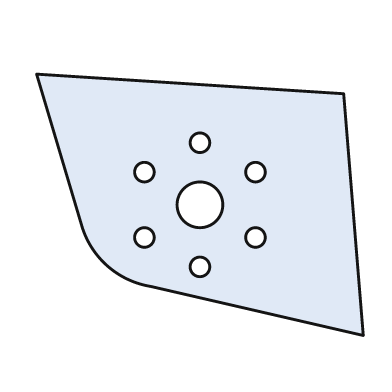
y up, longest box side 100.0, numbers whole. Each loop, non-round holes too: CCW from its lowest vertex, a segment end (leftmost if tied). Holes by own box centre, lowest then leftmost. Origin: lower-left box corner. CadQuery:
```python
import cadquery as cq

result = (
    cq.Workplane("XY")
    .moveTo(100.0, 0.0)
    .lineTo(94.0, 74.0)
    .lineTo(0.0, 80.0)
    .lineTo(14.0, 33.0)
    .threePointArc((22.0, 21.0), (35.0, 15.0))
    .close()
    .moveTo(50.0, 21.0)
    .circle(3.0)
    .moveTo(33.0, 30.0)
    .circle(3.0)
    .moveTo(67.0, 30.0)
    .circle(3.0)
    .moveTo(50.0, 40.0)
    .circle(7.0)
    .moveTo(33.0, 50.0)
    .circle(3.0)
    .moveTo(67.0, 50.0)
    .circle(3.0)
    .moveTo(50.0, 59.0)
    .circle(3.0)
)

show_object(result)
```